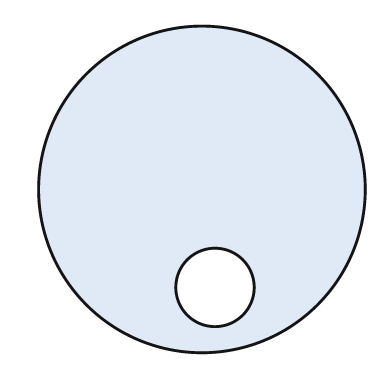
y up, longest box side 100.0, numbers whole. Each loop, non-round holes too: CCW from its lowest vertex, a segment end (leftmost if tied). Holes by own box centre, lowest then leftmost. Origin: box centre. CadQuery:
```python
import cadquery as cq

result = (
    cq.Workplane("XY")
    .moveTo(0.0, 0.0)
    .circle(50.0)
    .moveTo(4.0, -30.0)
    .circle(12.0)
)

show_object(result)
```